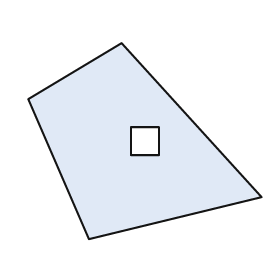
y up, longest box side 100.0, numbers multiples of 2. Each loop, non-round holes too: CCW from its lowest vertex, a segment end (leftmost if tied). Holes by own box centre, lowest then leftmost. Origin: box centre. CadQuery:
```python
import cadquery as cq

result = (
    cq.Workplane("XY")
    .moveTo(-24.0, -42.0)
    .lineTo(50.0, -24.0)
    .lineTo(-10.0, 42.0)
    .lineTo(-50.0, 18.0)
    .close()
    .moveTo(-6.0, -6.0)
    .lineTo(6.0, -6.0)
    .lineTo(6.0, 6.0)
    .lineTo(-6.0, 6.0)
    .close()
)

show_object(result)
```